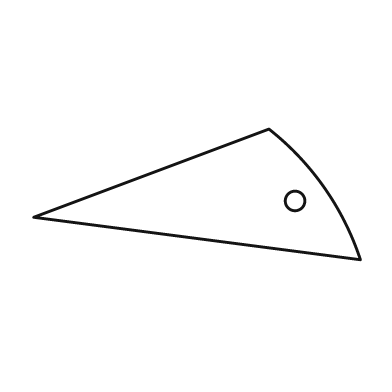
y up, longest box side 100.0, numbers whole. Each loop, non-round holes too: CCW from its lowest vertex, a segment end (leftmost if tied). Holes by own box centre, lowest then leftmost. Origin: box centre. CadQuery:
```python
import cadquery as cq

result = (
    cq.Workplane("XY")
    .moveTo(50.0, -20.0)
    .threePointArc((39.0, 2.0), (22.0, 20.0))
    .lineTo(-50.0, -7.0)
    .close()
    .moveTo(30.0, -2.0)
    .circle(3.0)
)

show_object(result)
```